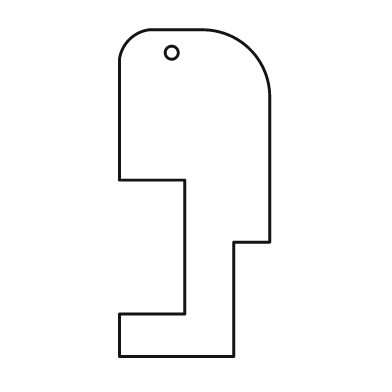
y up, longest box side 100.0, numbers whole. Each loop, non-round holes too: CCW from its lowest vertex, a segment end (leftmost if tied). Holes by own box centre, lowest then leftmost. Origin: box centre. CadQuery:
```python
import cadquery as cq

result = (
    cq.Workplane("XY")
    .moveTo(-23.0, -50.0)
    .lineTo(12.0, -50.0)
    .lineTo(12.0, -15.0)
    .lineTo(23.0, -15.0)
    .lineTo(23.0, 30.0)
    .threePointArc((17.0, 44.0), (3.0, 50.0))
    .lineTo(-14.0, 50.0)
    .threePointArc((-20.0, 47.0), (-23.0, 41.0))
    .lineTo(-23.0, 4.0)
    .lineTo(-3.0, 4.0)
    .lineTo(-3.0, -37.0)
    .lineTo(-23.0, -37.0)
    .close()
    .moveTo(-7.0, 43.0)
    .circle(2.0)
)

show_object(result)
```